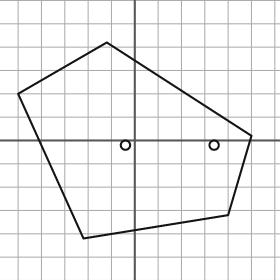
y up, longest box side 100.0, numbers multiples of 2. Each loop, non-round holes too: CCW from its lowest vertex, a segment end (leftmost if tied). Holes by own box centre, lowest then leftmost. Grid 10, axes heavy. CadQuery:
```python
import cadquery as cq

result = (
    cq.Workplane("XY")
    .moveTo(-22.0, -42.0)
    .lineTo(40.0, -32.0)
    .lineTo(50.0, 2.0)
    .lineTo(-12.0, 42.0)
    .lineTo(-50.0, 20.0)
    .close()
    .moveTo(-4.0, -2.0)
    .circle(2.0)
    .moveTo(34.0, -2.0)
    .circle(2.0)
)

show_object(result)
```